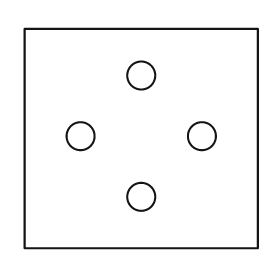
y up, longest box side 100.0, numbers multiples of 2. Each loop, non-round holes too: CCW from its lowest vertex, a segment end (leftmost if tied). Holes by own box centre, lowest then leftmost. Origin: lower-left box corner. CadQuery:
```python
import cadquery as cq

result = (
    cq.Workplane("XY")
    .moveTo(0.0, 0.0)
    .lineTo(100.0, 0.0)
    .lineTo(100.0, 94.0)
    .lineTo(0.0, 94.0)
    .close()
    .moveTo(50.0, 22.0)
    .circle(6.0)
    .moveTo(24.0, 48.0)
    .circle(6.0)
    .moveTo(76.0, 48.0)
    .circle(6.0)
    .moveTo(50.0, 74.0)
    .circle(6.0)
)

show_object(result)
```